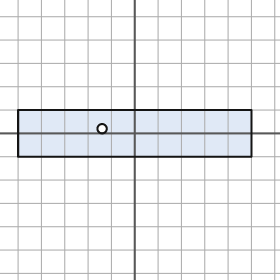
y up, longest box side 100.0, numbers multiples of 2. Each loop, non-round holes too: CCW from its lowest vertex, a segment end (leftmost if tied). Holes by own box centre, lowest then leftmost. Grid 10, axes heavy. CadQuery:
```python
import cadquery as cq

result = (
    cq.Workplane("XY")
    .moveTo(-50.0, -10.0)
    .lineTo(50.0, -10.0)
    .lineTo(50.0, 10.0)
    .lineTo(-50.0, 10.0)
    .close()
    .moveTo(-14.0, 2.0)
    .circle(2.0)
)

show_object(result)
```